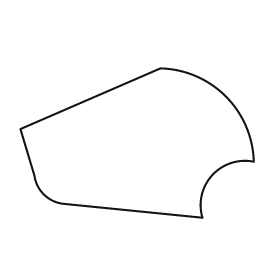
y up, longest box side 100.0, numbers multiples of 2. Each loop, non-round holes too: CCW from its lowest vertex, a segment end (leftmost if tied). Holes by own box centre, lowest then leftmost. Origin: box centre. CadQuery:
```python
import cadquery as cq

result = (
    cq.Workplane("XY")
    .moveTo(28.0, -32.0)
    .threePointArc((32.0, -14.0), (50.0, -8.0))
    .threePointArc((38.0, 20.0), (10.0, 32.0))
    .lineTo(-50.0, 6.0)
    .lineTo(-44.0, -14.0)
    .threePointArc((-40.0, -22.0), (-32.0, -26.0))
    .close()
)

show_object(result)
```